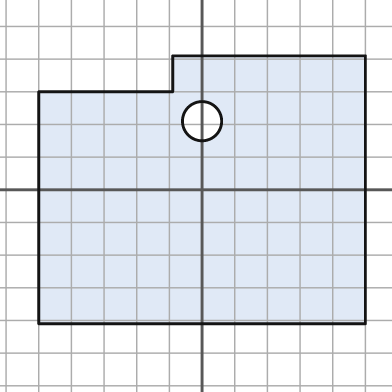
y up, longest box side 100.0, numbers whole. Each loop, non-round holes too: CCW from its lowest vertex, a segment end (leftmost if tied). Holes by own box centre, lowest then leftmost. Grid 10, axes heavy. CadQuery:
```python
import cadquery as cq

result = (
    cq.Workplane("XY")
    .moveTo(-50.0, -41.0)
    .lineTo(50.0, -41.0)
    .lineTo(50.0, 41.0)
    .lineTo(-9.0, 41.0)
    .lineTo(-9.0, 30.0)
    .lineTo(-50.0, 30.0)
    .close()
    .moveTo(0.0, 21.0)
    .circle(6.0)
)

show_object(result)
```